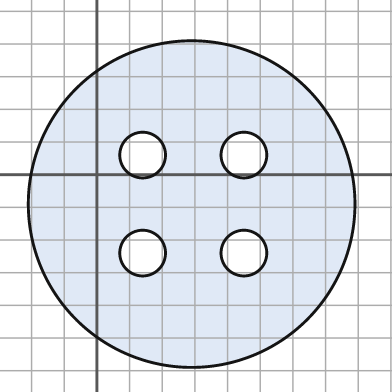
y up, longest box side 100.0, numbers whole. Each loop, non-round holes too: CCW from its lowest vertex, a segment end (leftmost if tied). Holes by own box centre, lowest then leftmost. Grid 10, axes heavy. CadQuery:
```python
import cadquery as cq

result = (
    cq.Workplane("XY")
    .moveTo(29.0, -9.0)
    .circle(50.0)
    .moveTo(14.0, -24.0)
    .circle(7.0)
    .moveTo(45.0, -24.0)
    .circle(7.0)
    .moveTo(14.0, 6.0)
    .circle(7.0)
    .moveTo(45.0, 6.0)
    .circle(7.0)
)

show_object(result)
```